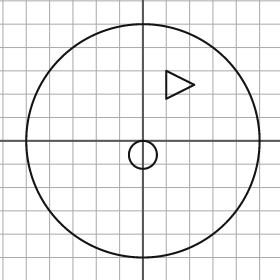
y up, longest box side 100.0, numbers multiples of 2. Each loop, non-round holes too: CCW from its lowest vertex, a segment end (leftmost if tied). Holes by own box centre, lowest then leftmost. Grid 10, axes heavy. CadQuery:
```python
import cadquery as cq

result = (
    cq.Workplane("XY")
    .moveTo(0.0, 0.0)
    .circle(50.0)
    .moveTo(0.0, -6.0)
    .circle(6.0)
    .moveTo(10.0, 18.0)
    .lineTo(22.0, 24.0)
    .lineTo(10.0, 30.0)
    .close()
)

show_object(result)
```